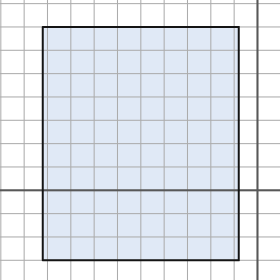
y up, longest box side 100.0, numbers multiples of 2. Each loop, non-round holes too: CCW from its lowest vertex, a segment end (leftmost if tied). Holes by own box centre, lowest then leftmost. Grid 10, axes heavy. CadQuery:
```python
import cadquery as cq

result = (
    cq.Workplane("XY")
    .moveTo(-92.0, -30.0)
    .lineTo(-8.0, -30.0)
    .lineTo(-8.0, 70.0)
    .lineTo(-92.0, 70.0)
    .close()
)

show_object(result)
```